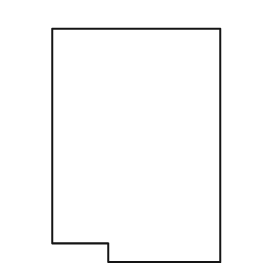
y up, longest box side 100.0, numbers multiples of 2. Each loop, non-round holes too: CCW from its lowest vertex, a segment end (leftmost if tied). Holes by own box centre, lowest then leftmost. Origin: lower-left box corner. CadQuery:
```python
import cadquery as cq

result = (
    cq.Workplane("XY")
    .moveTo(24.0, 0.0)
    .lineTo(72.0, 0.0)
    .lineTo(72.0, 100.0)
    .lineTo(0.0, 100.0)
    .lineTo(0.0, 8.0)
    .lineTo(24.0, 8.0)
    .close()
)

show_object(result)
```